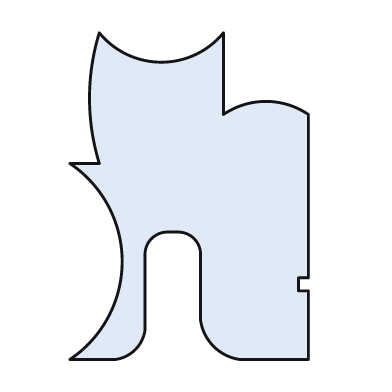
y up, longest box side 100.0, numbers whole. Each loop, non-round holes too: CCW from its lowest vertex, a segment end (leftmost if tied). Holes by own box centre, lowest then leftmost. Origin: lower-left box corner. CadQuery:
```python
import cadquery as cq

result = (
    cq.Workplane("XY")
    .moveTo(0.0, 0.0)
    .lineTo(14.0, 0.0)
    .threePointArc((20.0, 3.0), (23.0, 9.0))
    .lineTo(23.0, 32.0)
    .threePointArc((25.0, 37.0), (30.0, 39.0))
    .lineTo(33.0, 39.0)
    .threePointArc((38.0, 37.0), (40.0, 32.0))
    .lineTo(40.0, 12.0)
    .threePointArc((44.0, 4.0), (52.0, 0.0))
    .lineTo(73.0, 0.0)
    .lineTo(73.0, 21.0)
    .lineTo(70.0, 21.0)
    .lineTo(70.0, 25.0)
    .lineTo(73.0, 25.0)
    .lineTo(73.0, 75.0)
    .threePointArc((60.0, 79.0), (47.0, 75.0))
    .lineTo(47.0, 100.0)
    .threePointArc((28.0, 91.0), (9.0, 100.0))
    .threePointArc((6.0, 80.0), (9.0, 60.0))
    .lineTo(0.0, 60.0)
    .threePointArc((16.0, 30.0), (0.0, 0.0))
    .close()
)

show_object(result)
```